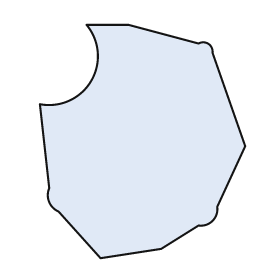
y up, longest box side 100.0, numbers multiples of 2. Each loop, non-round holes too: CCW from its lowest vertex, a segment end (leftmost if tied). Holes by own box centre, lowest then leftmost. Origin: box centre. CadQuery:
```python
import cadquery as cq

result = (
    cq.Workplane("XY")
    .moveTo(-18.0, -50.0)
    .lineTo(8.0, -46.0)
    .lineTo(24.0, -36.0)
    .threePointArc((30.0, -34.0), (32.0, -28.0))
    .lineTo(44.0, -2.0)
    .lineTo(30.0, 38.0)
    .threePointArc((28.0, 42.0), (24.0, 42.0))
    .lineTo(-6.0, 50.0)
    .lineTo(-24.0, 50.0)
    .threePointArc((-22.0, 26.0), (-44.0, 16.0))
    .lineTo(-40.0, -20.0)
    .threePointArc((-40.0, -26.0), (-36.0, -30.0))
    .close()
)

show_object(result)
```